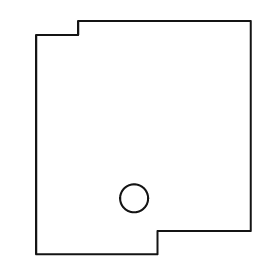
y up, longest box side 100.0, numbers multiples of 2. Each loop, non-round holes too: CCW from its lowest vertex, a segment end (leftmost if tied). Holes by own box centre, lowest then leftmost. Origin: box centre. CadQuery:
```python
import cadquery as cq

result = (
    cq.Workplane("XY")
    .moveTo(-46.0, -50.0)
    .lineTo(6.0, -50.0)
    .lineTo(6.0, -40.0)
    .lineTo(46.0, -40.0)
    .lineTo(46.0, 50.0)
    .lineTo(-28.0, 50.0)
    .lineTo(-28.0, 44.0)
    .lineTo(-46.0, 44.0)
    .close()
    .moveTo(-4.0, -26.0)
    .circle(6.0)
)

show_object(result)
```